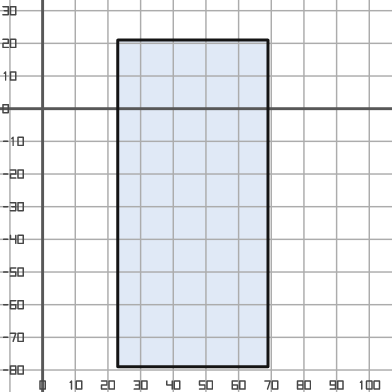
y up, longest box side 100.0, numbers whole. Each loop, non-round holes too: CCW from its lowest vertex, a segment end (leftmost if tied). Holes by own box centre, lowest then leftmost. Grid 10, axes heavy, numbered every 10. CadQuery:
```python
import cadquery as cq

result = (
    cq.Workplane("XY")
    .moveTo(23.0, -79.0)
    .lineTo(69.0, -79.0)
    .lineTo(69.0, 21.0)
    .lineTo(23.0, 21.0)
    .close()
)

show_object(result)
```